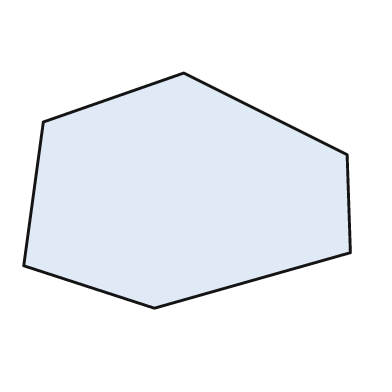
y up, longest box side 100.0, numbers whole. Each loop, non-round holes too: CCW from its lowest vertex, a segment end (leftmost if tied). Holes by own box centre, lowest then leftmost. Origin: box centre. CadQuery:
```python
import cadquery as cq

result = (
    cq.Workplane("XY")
    .moveTo(-10.0, -36.0)
    .lineTo(50.0, -19.0)
    .lineTo(49.0, 11.0)
    .lineTo(-1.0, 36.0)
    .lineTo(-44.0, 21.0)
    .lineTo(-50.0, -23.0)
    .close()
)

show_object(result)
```